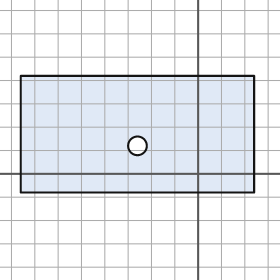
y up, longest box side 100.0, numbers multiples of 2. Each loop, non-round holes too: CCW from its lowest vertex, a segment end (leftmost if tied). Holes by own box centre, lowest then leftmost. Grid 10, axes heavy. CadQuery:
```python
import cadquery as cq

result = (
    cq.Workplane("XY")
    .moveTo(-76.0, -8.0)
    .lineTo(24.0, -8.0)
    .lineTo(24.0, 42.0)
    .lineTo(-76.0, 42.0)
    .close()
    .moveTo(-26.0, 12.0)
    .circle(4.0)
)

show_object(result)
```